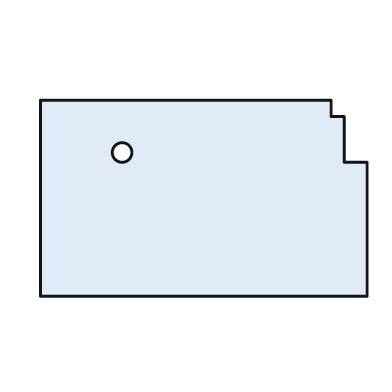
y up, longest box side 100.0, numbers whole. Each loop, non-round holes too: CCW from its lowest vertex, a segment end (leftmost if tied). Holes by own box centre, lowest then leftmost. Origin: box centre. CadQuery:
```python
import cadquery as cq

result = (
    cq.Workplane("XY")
    .moveTo(-50.0, -30.0)
    .lineTo(50.0, -30.0)
    .lineTo(50.0, 11.0)
    .lineTo(43.0, 11.0)
    .lineTo(43.0, 25.0)
    .lineTo(39.0, 25.0)
    .lineTo(39.0, 30.0)
    .lineTo(-50.0, 30.0)
    .close()
    .moveTo(-25.0, 14.0)
    .circle(3.0)
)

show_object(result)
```